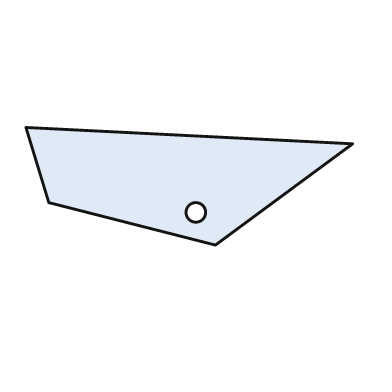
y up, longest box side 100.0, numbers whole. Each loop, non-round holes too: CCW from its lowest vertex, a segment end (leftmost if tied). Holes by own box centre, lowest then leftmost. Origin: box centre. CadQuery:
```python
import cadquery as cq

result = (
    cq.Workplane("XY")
    .moveTo(8.0, -18.0)
    .lineTo(50.0, 13.0)
    .lineTo(-50.0, 18.0)
    .lineTo(-43.0, -5.0)
    .close()
    .moveTo(2.0, -8.0)
    .circle(3.0)
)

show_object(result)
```